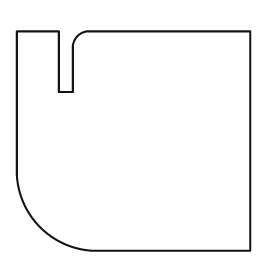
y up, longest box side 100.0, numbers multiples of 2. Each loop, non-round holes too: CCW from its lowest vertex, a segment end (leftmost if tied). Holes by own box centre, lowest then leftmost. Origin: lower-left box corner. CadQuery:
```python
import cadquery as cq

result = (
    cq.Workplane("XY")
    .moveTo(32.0, 0.0)
    .lineTo(100.0, 0.0)
    .lineTo(100.0, 94.0)
    .lineTo(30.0, 94.0)
    .threePointArc((26.0, 92.0), (24.0, 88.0))
    .lineTo(24.0, 68.0)
    .lineTo(18.0, 68.0)
    .lineTo(18.0, 94.0)
    .lineTo(0.0, 94.0)
    .lineTo(0.0, 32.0)
    .threePointArc((10.0, 10.0), (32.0, 0.0))
    .close()
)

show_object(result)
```